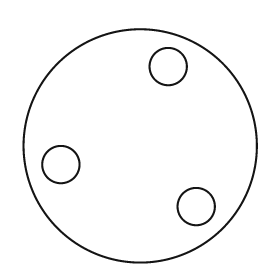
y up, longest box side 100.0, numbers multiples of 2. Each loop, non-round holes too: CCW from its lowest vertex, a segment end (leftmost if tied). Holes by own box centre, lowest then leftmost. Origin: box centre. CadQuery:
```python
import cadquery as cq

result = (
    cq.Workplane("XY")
    .moveTo(0.0, 0.0)
    .circle(50.0)
    .moveTo(24.0, -26.0)
    .circle(8.0)
    .moveTo(-34.0, -8.0)
    .circle(8.0)
    .moveTo(12.0, 34.0)
    .circle(8.0)
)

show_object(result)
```